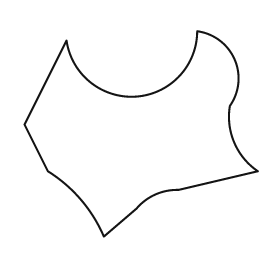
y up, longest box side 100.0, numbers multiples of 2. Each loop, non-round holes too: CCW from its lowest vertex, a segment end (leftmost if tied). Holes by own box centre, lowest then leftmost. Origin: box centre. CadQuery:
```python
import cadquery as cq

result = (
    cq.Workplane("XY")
    .moveTo(-16.0, -44.0)
    .lineTo(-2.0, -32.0)
    .threePointArc((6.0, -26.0), (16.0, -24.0))
    .lineTo(50.0, -16.0)
    .threePointArc((40.0, -4.0), (38.0, 12.0))
    .threePointArc((40.0, 32.0), (24.0, 44.0))
    .threePointArc((-2.0, 16.0), (-32.0, 40.0))
    .lineTo(-50.0, 4.0)
    .lineTo(-40.0, -16.0)
    .threePointArc((-26.0, -28.0), (-16.0, -44.0))
    .close()
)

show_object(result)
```